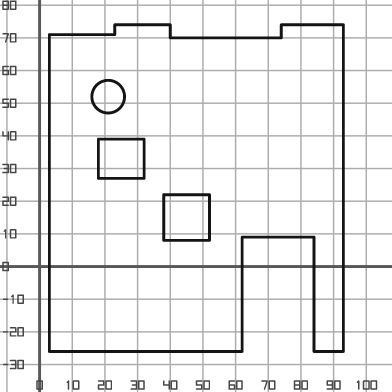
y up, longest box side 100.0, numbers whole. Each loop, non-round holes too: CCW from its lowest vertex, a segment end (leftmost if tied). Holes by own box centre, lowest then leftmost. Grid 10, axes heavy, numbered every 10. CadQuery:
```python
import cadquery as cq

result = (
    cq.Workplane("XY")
    .moveTo(3.0, -26.0)
    .lineTo(62.0, -26.0)
    .lineTo(62.0, 9.0)
    .lineTo(84.0, 9.0)
    .lineTo(84.0, -26.0)
    .lineTo(93.0, -26.0)
    .lineTo(93.0, 74.0)
    .lineTo(74.0, 74.0)
    .lineTo(74.0, 70.0)
    .lineTo(40.0, 70.0)
    .lineTo(40.0, 74.0)
    .lineTo(23.0, 74.0)
    .lineTo(23.0, 71.0)
    .lineTo(3.0, 71.0)
    .close()
    .moveTo(38.0, 8.0)
    .lineTo(52.0, 8.0)
    .lineTo(52.0, 22.0)
    .lineTo(38.0, 22.0)
    .close()
    .moveTo(18.0, 27.0)
    .lineTo(32.0, 27.0)
    .lineTo(32.0, 39.0)
    .lineTo(18.0, 39.0)
    .close()
    .moveTo(21.0, 52.0)
    .circle(5.0)
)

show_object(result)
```